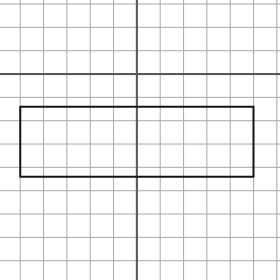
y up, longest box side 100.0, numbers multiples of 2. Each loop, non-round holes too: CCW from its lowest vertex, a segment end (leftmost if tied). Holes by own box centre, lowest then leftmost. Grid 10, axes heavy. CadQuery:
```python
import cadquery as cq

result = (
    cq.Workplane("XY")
    .moveTo(-50.0, -44.0)
    .lineTo(50.0, -44.0)
    .lineTo(50.0, -14.0)
    .lineTo(-50.0, -14.0)
    .close()
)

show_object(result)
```